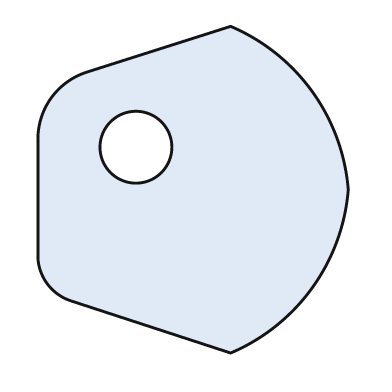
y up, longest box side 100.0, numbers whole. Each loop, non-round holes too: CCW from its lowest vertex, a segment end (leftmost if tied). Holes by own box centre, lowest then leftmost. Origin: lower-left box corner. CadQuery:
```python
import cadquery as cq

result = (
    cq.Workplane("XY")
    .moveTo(59.0, 0.0)
    .threePointArc((84.0, 20.0), (95.0, 50.0))
    .threePointArc((84.0, 80.0), (59.0, 100.0))
    .lineTo(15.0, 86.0)
    .threePointArc((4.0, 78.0), (0.0, 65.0))
    .lineTo(0.0, 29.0)
    .threePointArc((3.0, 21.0), (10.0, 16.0))
    .close()
    .moveTo(30.0, 63.0)
    .circle(11.0)
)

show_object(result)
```